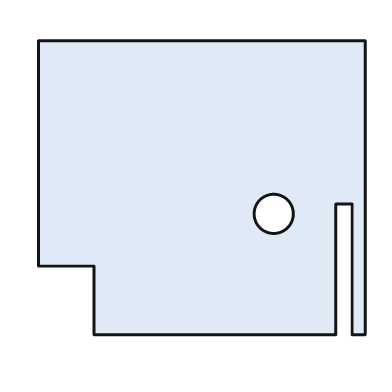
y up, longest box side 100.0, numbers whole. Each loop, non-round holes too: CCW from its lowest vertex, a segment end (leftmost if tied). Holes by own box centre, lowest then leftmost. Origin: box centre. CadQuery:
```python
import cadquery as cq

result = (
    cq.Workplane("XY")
    .moveTo(-33.0, -45.0)
    .lineTo(41.0, -45.0)
    .lineTo(41.0, -5.0)
    .lineTo(46.0, -5.0)
    .lineTo(46.0, -45.0)
    .lineTo(50.0, -45.0)
    .lineTo(50.0, 45.0)
    .lineTo(-50.0, 45.0)
    .lineTo(-50.0, -24.0)
    .lineTo(-33.0, -24.0)
    .close()
    .moveTo(22.0, -8.0)
    .circle(6.0)
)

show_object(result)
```